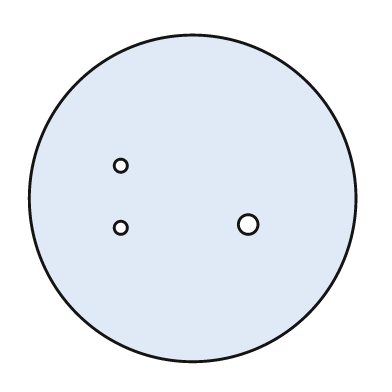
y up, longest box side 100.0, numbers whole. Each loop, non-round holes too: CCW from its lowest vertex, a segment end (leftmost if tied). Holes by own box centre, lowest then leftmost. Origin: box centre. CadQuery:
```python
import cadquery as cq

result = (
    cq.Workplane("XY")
    .moveTo(0.0, 0.0)
    .circle(50.0)
    .moveTo(-22.0, -9.0)
    .circle(2.0)
    .moveTo(17.0, -8.0)
    .circle(3.0)
    .moveTo(-22.0, 10.0)
    .circle(2.0)
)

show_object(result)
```